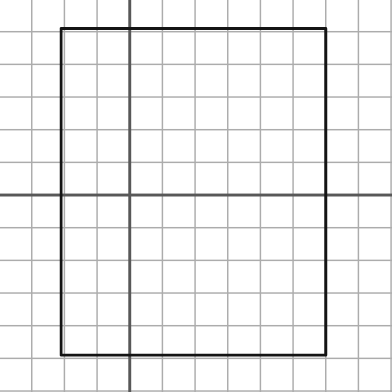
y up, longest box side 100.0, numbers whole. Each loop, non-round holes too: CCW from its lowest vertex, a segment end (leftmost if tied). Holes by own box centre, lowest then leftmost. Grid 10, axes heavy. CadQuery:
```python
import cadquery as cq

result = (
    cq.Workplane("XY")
    .moveTo(-21.0, -49.0)
    .lineTo(60.0, -49.0)
    .lineTo(60.0, 51.0)
    .lineTo(-21.0, 51.0)
    .close()
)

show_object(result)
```